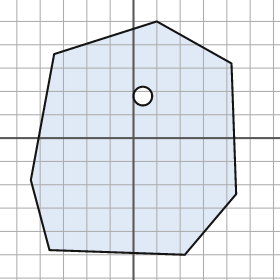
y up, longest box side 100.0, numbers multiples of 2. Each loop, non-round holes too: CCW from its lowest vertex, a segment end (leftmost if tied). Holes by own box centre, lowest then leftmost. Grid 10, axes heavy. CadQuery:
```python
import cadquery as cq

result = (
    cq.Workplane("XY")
    .moveTo(22.0, -50.0)
    .lineTo(44.0, -24.0)
    .lineTo(42.0, 32.0)
    .lineTo(10.0, 50.0)
    .lineTo(-34.0, 36.0)
    .lineTo(-44.0, -18.0)
    .lineTo(-36.0, -48.0)
    .close()
    .moveTo(4.0, 18.0)
    .circle(4.0)
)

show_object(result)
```